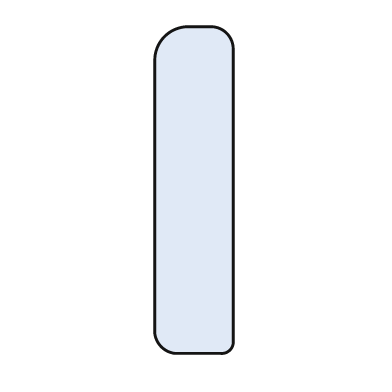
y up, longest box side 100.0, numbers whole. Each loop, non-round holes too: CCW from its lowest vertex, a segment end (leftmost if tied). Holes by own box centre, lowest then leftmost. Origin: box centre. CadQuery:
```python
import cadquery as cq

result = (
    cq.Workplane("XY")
    .moveTo(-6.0, -50.0)
    .lineTo(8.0, -50.0)
    .threePointArc((11.0, -49.0), (12.0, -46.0))
    .lineTo(12.0, 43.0)
    .threePointArc((10.0, 48.0), (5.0, 50.0))
    .lineTo(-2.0, 50.0)
    .threePointArc((-9.0, 47.0), (-12.0, 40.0))
    .lineTo(-12.0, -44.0)
    .threePointArc((-10.0, -48.0), (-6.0, -50.0))
    .close()
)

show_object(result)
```